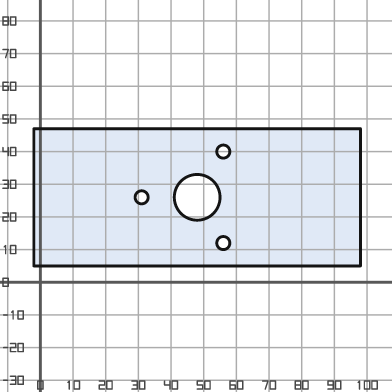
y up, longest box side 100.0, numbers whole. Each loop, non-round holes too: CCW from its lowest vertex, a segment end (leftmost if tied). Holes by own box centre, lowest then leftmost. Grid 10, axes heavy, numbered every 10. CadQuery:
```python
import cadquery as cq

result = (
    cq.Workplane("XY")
    .moveTo(-2.0, 5.0)
    .lineTo(98.0, 5.0)
    .lineTo(98.0, 47.0)
    .lineTo(-2.0, 47.0)
    .close()
    .moveTo(56.0, 12.0)
    .circle(2.0)
    .moveTo(31.0, 26.0)
    .circle(2.0)
    .moveTo(48.0, 26.0)
    .circle(7.0)
    .moveTo(56.0, 40.0)
    .circle(2.0)
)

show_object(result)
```